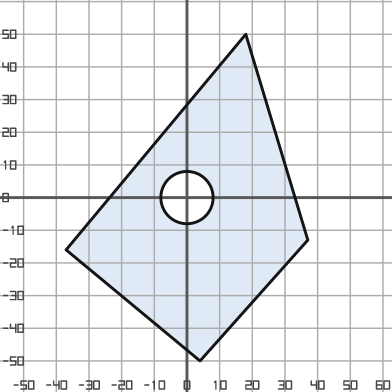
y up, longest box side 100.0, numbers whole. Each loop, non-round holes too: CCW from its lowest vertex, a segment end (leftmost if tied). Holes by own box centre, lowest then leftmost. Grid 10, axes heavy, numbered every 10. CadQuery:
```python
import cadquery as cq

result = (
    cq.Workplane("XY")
    .moveTo(4.0, -50.0)
    .lineTo(37.0, -13.0)
    .lineTo(18.0, 50.0)
    .lineTo(-37.0, -16.0)
    .close()
    .moveTo(0.0, 0.0)
    .circle(8.0)
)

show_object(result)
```